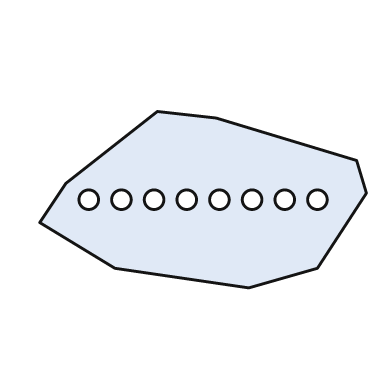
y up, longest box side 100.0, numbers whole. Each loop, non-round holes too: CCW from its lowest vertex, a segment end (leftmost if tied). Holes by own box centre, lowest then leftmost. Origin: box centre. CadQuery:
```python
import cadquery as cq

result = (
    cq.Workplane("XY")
    .moveTo(14.0, -27.0)
    .lineTo(35.0, -21.0)
    .lineTo(50.0, 2.0)
    .lineTo(47.0, 12.0)
    .lineTo(4.0, 25.0)
    .lineTo(-14.0, 27.0)
    .lineTo(-42.0, 5.0)
    .lineTo(-50.0, -7.0)
    .lineTo(-27.0, -21.0)
    .close()
    .moveTo(-35.0, 0.0)
    .circle(3.0)
    .moveTo(-25.0, 0.0)
    .circle(3.0)
    .moveTo(-15.0, 0.0)
    .circle(3.0)
    .moveTo(-5.0, 0.0)
    .circle(3.0)
    .moveTo(5.0, 0.0)
    .circle(3.0)
    .moveTo(15.0, 0.0)
    .circle(3.0)
    .moveTo(25.0, 0.0)
    .circle(3.0)
    .moveTo(35.0, 0.0)
    .circle(3.0)
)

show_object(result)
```